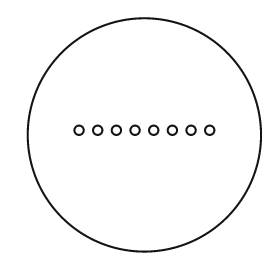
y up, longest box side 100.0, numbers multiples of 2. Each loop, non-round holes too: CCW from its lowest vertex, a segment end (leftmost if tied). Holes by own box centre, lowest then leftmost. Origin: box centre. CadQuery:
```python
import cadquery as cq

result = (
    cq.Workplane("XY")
    .moveTo(0.0, 0.0)
    .circle(50.0)
    .moveTo(-28.0, 2.0)
    .circle(2.0)
    .moveTo(-20.0, 2.0)
    .circle(2.0)
    .moveTo(-12.0, 2.0)
    .circle(2.0)
    .moveTo(-4.0, 2.0)
    .circle(2.0)
    .moveTo(4.0, 2.0)
    .circle(2.0)
    .moveTo(12.0, 2.0)
    .circle(2.0)
    .moveTo(20.0, 2.0)
    .circle(2.0)
    .moveTo(28.0, 2.0)
    .circle(2.0)
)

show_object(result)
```